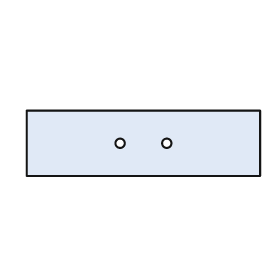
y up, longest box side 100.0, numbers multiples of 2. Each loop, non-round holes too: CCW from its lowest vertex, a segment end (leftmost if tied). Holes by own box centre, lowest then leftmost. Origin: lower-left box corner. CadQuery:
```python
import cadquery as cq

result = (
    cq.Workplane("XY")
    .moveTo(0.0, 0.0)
    .lineTo(100.0, 0.0)
    .lineTo(100.0, 28.0)
    .lineTo(0.0, 28.0)
    .close()
    .moveTo(40.0, 14.0)
    .circle(2.0)
    .moveTo(60.0, 14.0)
    .circle(2.0)
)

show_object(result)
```